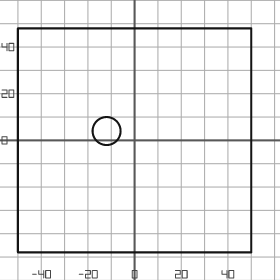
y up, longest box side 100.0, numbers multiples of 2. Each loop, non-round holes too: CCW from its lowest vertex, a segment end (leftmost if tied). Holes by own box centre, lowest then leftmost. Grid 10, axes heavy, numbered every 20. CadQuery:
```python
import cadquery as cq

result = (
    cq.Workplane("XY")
    .moveTo(-50.0, -48.0)
    .lineTo(50.0, -48.0)
    .lineTo(50.0, 48.0)
    .lineTo(-50.0, 48.0)
    .close()
    .moveTo(-12.0, 4.0)
    .circle(6.0)
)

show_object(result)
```